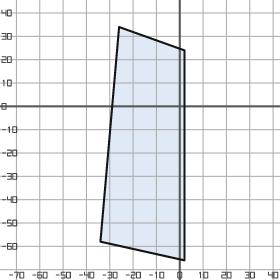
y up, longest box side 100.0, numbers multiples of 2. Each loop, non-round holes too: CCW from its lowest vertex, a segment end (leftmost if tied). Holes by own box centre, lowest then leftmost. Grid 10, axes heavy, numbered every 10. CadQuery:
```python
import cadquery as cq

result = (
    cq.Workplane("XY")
    .moveTo(2.0, -66.0)
    .lineTo(2.0, 24.0)
    .lineTo(-26.0, 34.0)
    .lineTo(-34.0, -58.0)
    .close()
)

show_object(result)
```